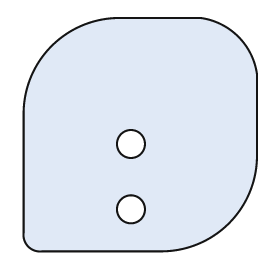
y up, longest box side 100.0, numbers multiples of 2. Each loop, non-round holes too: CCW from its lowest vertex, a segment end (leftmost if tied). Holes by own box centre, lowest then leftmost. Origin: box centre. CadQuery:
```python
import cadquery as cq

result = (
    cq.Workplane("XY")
    .moveTo(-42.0, -50.0)
    .lineTo(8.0, -50.0)
    .threePointArc((38.0, -38.0), (50.0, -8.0))
    .lineTo(50.0, 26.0)
    .threePointArc((42.0, 42.0), (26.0, 50.0))
    .lineTo(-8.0, 50.0)
    .threePointArc((-38.0, 38.0), (-50.0, 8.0))
    .lineTo(-50.0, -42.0)
    .threePointArc((-48.0, -48.0), (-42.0, -50.0))
    .close()
    .moveTo(-4.0, -32.0)
    .circle(6.0)
    .moveTo(-4.0, -4.0)
    .circle(6.0)
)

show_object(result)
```